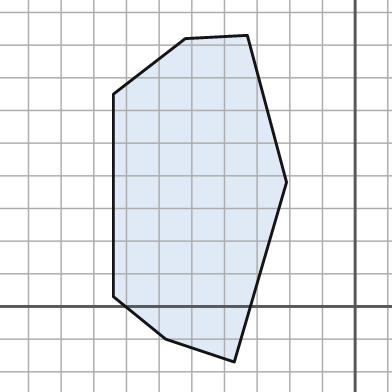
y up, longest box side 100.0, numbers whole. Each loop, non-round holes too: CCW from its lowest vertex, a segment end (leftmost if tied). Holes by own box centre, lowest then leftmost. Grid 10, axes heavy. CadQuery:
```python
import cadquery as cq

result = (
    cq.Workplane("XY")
    .moveTo(-37.0, -17.0)
    .lineTo(-21.0, 38.0)
    .lineTo(-33.0, 83.0)
    .lineTo(-52.0, 82.0)
    .lineTo(-74.0, 65.0)
    .lineTo(-74.0, 3.0)
    .lineTo(-58.0, -10.0)
    .close()
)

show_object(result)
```